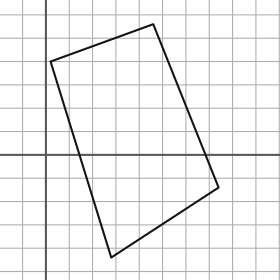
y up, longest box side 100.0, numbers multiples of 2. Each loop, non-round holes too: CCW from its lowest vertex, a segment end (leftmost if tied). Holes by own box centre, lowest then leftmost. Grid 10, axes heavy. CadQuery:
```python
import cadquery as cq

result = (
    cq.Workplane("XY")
    .moveTo(28.0, -44.0)
    .lineTo(74.0, -14.0)
    .lineTo(46.0, 56.0)
    .lineTo(2.0, 40.0)
    .close()
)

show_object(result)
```